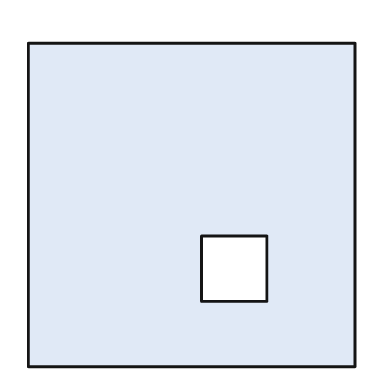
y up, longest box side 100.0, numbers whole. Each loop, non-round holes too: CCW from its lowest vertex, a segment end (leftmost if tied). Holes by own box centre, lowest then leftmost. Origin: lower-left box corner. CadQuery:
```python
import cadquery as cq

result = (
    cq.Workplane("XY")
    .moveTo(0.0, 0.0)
    .lineTo(100.0, 0.0)
    .lineTo(100.0, 99.0)
    .lineTo(0.0, 99.0)
    .close()
    .moveTo(53.0, 20.0)
    .lineTo(73.0, 20.0)
    .lineTo(73.0, 40.0)
    .lineTo(53.0, 40.0)
    .close()
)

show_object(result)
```